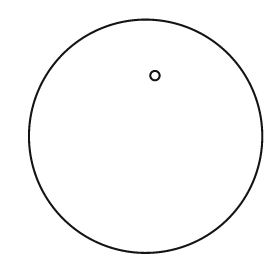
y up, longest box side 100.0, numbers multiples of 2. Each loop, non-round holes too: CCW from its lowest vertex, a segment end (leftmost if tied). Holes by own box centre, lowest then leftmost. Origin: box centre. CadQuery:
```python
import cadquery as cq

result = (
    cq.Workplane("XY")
    .moveTo(0.0, 0.0)
    .circle(50.0)
    .moveTo(4.0, 26.0)
    .circle(2.0)
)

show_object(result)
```